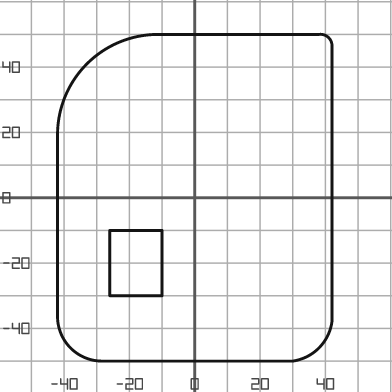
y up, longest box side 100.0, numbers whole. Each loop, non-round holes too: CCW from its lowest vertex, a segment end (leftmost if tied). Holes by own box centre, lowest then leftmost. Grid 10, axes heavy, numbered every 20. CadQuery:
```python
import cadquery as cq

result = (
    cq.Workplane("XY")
    .moveTo(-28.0, -50.0)
    .lineTo(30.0, -50.0)
    .threePointArc((38.0, -46.0), (42.0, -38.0))
    .lineTo(42.0, 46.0)
    .threePointArc((41.0, 49.0), (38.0, 50.0))
    .lineTo(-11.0, 50.0)
    .threePointArc((-33.0, 41.0), (-42.0, 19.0))
    .lineTo(-42.0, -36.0)
    .threePointArc((-38.0, -46.0), (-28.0, -50.0))
    .close()
    .moveTo(-26.0, -30.0)
    .lineTo(-10.0, -30.0)
    .lineTo(-10.0, -10.0)
    .lineTo(-26.0, -10.0)
    .close()
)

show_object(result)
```